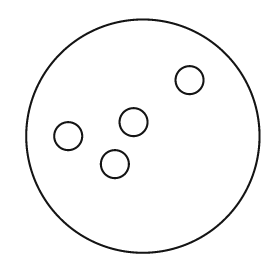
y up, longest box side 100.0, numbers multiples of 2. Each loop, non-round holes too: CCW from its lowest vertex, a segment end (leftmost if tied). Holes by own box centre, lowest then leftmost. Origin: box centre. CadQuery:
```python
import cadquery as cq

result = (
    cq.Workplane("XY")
    .moveTo(0.0, 0.0)
    .circle(50.0)
    .moveTo(-12.0, -12.0)
    .circle(6.0)
    .moveTo(-32.0, 0.0)
    .circle(6.0)
    .moveTo(-4.0, 6.0)
    .circle(6.0)
    .moveTo(20.0, 24.0)
    .circle(6.0)
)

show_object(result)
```